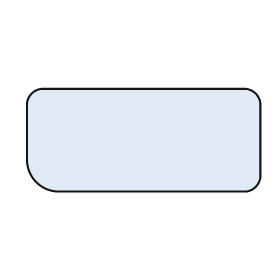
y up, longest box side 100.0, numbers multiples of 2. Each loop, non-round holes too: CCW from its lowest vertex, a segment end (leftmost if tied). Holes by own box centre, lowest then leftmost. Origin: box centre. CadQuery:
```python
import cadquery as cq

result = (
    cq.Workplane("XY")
    .moveTo(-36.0, -22.0)
    .lineTo(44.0, -22.0)
    .threePointArc((48.0, -20.0), (50.0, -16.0))
    .lineTo(50.0, 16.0)
    .threePointArc((48.0, 20.0), (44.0, 22.0))
    .lineTo(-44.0, 22.0)
    .threePointArc((-48.0, 20.0), (-50.0, 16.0))
    .lineTo(-50.0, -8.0)
    .threePointArc((-46.0, -18.0), (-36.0, -22.0))
    .close()
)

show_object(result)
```